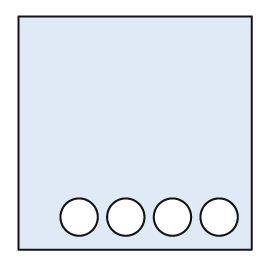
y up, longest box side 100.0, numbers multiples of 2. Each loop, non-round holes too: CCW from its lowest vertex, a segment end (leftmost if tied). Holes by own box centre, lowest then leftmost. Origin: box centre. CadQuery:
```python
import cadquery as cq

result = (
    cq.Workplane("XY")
    .moveTo(-50.0, -50.0)
    .lineTo(50.0, -50.0)
    .lineTo(50.0, 50.0)
    .lineTo(-50.0, 50.0)
    .close()
    .moveTo(-24.0, -36.0)
    .circle(8.0)
    .moveTo(-4.0, -36.0)
    .circle(8.0)
    .moveTo(16.0, -36.0)
    .circle(8.0)
    .moveTo(36.0, -36.0)
    .circle(8.0)
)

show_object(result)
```